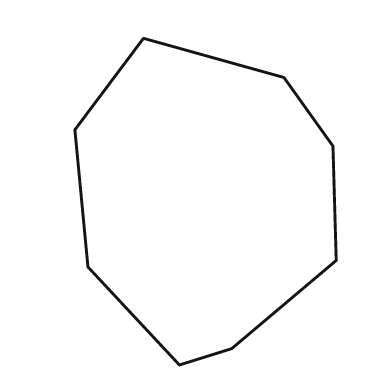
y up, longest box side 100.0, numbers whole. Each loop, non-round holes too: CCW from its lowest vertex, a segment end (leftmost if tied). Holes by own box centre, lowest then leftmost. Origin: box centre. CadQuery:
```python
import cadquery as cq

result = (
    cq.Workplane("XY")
    .moveTo(-8.0, -50.0)
    .lineTo(8.0, -45.0)
    .lineTo(40.0, -18.0)
    .lineTo(39.0, 17.0)
    .lineTo(24.0, 38.0)
    .lineTo(-19.0, 50.0)
    .lineTo(-40.0, 22.0)
    .lineTo(-36.0, -20.0)
    .close()
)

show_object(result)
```